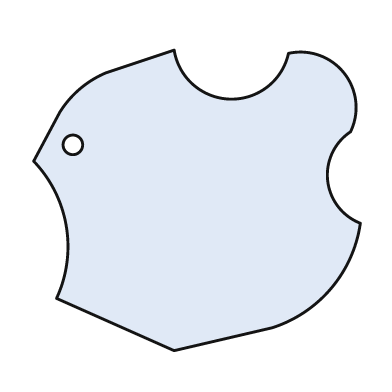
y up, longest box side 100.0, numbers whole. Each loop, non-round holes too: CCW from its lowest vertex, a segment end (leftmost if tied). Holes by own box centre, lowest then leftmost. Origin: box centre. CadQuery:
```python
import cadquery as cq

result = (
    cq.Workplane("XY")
    .moveTo(-7.0, -46.0)
    .lineTo(23.0, -39.0)
    .threePointArc((41.0, -27.0), (50.0, -7.0))
    .threePointArc((40.0, 6.0), (47.0, 21.0))
    .threePointArc((45.0, 39.0), (28.0, 45.0))
    .threePointArc((10.0, 31.0), (-7.0, 46.0))
    .lineTo(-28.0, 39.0)
    .threePointArc((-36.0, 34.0), (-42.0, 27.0))
    .lineTo(-50.0, 12.0)
    .threePointArc((-40.0, -8.0), (-43.0, -30.0))
    .close()
    .moveTo(-38.0, 17.0)
    .circle(3.0)
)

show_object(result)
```